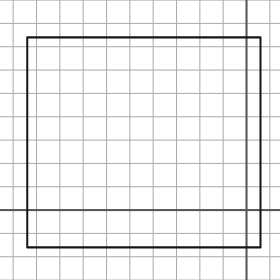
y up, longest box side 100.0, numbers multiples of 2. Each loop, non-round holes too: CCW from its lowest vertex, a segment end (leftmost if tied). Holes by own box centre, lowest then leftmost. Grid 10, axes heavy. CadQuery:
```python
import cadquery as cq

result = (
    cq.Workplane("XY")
    .moveTo(-94.0, -16.0)
    .lineTo(6.0, -16.0)
    .lineTo(6.0, 74.0)
    .lineTo(-94.0, 74.0)
    .close()
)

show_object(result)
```